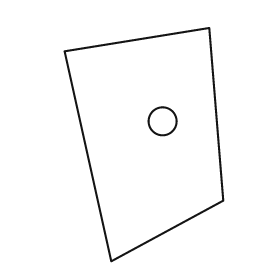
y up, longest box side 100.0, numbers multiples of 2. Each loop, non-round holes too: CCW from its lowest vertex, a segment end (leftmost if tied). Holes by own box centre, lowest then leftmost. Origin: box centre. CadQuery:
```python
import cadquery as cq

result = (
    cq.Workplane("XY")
    .moveTo(-14.0, -50.0)
    .lineTo(34.0, -24.0)
    .lineTo(28.0, 50.0)
    .lineTo(-34.0, 40.0)
    .close()
    .moveTo(8.0, 10.0)
    .circle(6.0)
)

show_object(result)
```